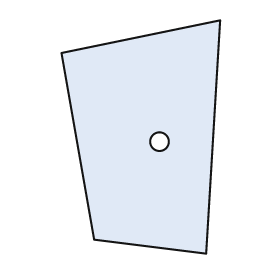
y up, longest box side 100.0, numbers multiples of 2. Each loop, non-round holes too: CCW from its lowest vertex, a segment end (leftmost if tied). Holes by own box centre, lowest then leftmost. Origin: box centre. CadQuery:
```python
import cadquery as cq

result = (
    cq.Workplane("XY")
    .moveTo(28.0, -50.0)
    .lineTo(34.0, 50.0)
    .lineTo(-34.0, 36.0)
    .lineTo(-20.0, -44.0)
    .close()
    .moveTo(8.0, -2.0)
    .circle(4.0)
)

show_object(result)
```